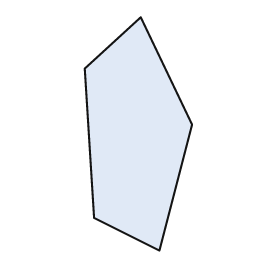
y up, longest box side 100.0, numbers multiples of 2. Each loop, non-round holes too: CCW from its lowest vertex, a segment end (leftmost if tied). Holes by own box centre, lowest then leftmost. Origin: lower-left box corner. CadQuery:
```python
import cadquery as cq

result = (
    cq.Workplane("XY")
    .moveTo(32.0, 0.0)
    .lineTo(46.0, 54.0)
    .lineTo(24.0, 100.0)
    .lineTo(0.0, 78.0)
    .lineTo(4.0, 14.0)
    .close()
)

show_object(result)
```